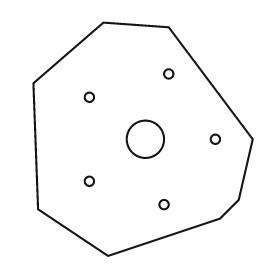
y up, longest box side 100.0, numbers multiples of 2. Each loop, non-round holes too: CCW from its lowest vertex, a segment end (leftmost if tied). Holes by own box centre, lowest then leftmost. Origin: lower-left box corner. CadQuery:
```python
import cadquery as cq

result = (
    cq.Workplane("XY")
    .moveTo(32.0, 0.0)
    .lineTo(80.0, 16.0)
    .lineTo(88.0, 24.0)
    .lineTo(94.0, 50.0)
    .lineTo(58.0, 98.0)
    .lineTo(30.0, 100.0)
    .lineTo(0.0, 74.0)
    .lineTo(2.0, 20.0)
    .close()
    .moveTo(56.0, 22.0)
    .circle(2.0)
    .moveTo(24.0, 32.0)
    .circle(2.0)
    .moveTo(48.0, 50.0)
    .circle(8.0)
    .moveTo(78.0, 50.0)
    .circle(2.0)
    .moveTo(24.0, 68.0)
    .circle(2.0)
    .moveTo(58.0, 78.0)
    .circle(2.0)
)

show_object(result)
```